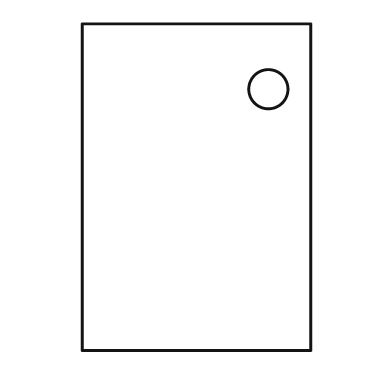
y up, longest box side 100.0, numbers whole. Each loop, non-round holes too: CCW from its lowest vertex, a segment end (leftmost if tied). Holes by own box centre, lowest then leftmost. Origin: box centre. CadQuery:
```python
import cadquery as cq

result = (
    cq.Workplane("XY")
    .moveTo(-35.0, -50.0)
    .lineTo(35.0, -50.0)
    .lineTo(35.0, 50.0)
    .lineTo(-35.0, 50.0)
    .close()
    .moveTo(22.0, 30.0)
    .circle(6.0)
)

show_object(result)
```